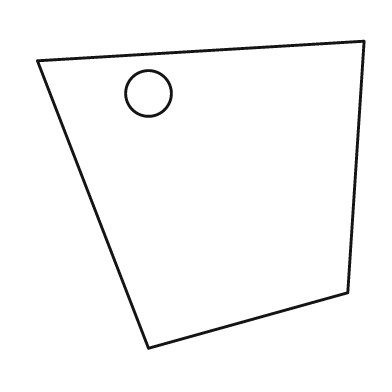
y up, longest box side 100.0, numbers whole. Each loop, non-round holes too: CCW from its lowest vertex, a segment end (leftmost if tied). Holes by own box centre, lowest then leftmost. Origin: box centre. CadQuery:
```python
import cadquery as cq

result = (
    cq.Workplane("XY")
    .moveTo(-16.0, -47.0)
    .lineTo(45.0, -30.0)
    .lineTo(50.0, 47.0)
    .lineTo(-50.0, 41.0)
    .close()
    .moveTo(-16.0, 31.0)
    .circle(7.0)
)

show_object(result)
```